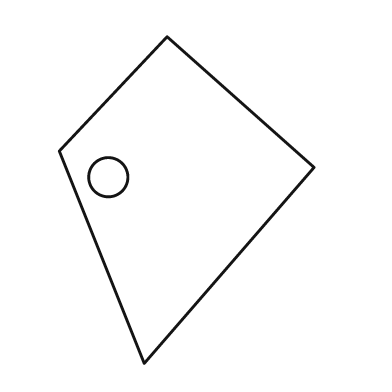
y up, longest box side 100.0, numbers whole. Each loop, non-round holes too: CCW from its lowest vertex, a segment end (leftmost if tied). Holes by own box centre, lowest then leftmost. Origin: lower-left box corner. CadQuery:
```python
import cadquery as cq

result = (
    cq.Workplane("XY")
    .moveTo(26.0, 0.0)
    .lineTo(78.0, 60.0)
    .lineTo(33.0, 100.0)
    .lineTo(0.0, 65.0)
    .close()
    .moveTo(15.0, 57.0)
    .circle(6.0)
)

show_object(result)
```